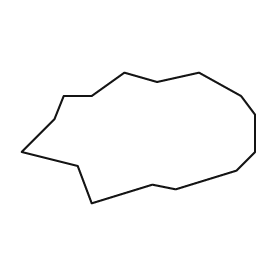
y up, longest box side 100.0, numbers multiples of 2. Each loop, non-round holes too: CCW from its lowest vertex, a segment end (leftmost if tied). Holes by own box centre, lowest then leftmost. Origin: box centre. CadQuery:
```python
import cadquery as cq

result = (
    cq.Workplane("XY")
    .moveTo(-20.0, -28.0)
    .lineTo(6.0, -20.0)
    .lineTo(16.0, -22.0)
    .lineTo(42.0, -14.0)
    .lineTo(50.0, -6.0)
    .lineTo(50.0, 10.0)
    .lineTo(44.0, 18.0)
    .lineTo(26.0, 28.0)
    .lineTo(8.0, 24.0)
    .lineTo(-6.0, 28.0)
    .lineTo(-20.0, 18.0)
    .lineTo(-32.0, 18.0)
    .lineTo(-36.0, 8.0)
    .lineTo(-50.0, -6.0)
    .lineTo(-26.0, -12.0)
    .close()
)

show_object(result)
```